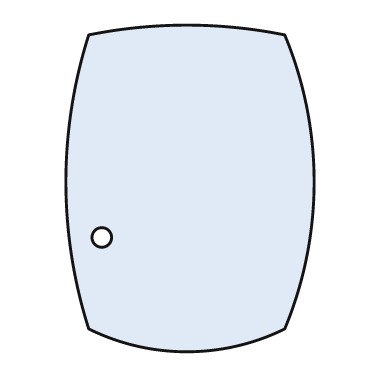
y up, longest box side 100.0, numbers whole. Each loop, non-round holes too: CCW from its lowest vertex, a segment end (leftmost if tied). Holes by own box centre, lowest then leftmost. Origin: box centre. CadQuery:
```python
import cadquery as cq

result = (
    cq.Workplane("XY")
    .moveTo(-31.0, -43.0)
    .threePointArc((-1.0, -50.0), (29.0, -43.0))
    .threePointArc((38.0, 2.0), (29.0, 47.0))
    .threePointArc((-1.0, 50.0), (-31.0, 47.0))
    .threePointArc((-38.0, 2.0), (-31.0, -43.0))
    .close()
    .moveTo(-27.0, -15.0)
    .circle(3.0)
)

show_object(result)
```